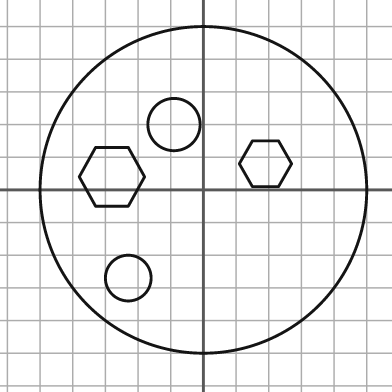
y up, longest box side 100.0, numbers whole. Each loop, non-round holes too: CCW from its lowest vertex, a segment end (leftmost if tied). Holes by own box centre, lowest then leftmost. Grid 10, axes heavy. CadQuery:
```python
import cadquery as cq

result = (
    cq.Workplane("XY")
    .moveTo(0.0, 0.0)
    .circle(50.0)
    .moveTo(-23.0, -27.0)
    .circle(7.0)
    .moveTo(-33.0, -5.0)
    .lineTo(-23.0, -5.0)
    .lineTo(-18.0, 4.0)
    .lineTo(-23.0, 13.0)
    .lineTo(-33.0, 13.0)
    .lineTo(-38.0, 4.0)
    .close()
    .moveTo(15.0, 1.0)
    .lineTo(23.0, 1.0)
    .lineTo(27.0, 8.0)
    .lineTo(23.0, 15.0)
    .lineTo(15.0, 15.0)
    .lineTo(11.0, 8.0)
    .close()
    .moveTo(-9.0, 20.0)
    .circle(8.0)
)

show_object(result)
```